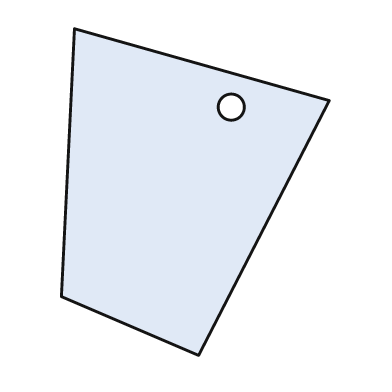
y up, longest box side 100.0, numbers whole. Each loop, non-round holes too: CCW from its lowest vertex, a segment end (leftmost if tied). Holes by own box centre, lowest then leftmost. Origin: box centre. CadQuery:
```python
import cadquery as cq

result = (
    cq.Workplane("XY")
    .moveTo(1.0, -50.0)
    .lineTo(41.0, 28.0)
    .lineTo(-37.0, 50.0)
    .lineTo(-41.0, -32.0)
    .close()
    .moveTo(11.0, 26.0)
    .circle(4.0)
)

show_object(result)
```